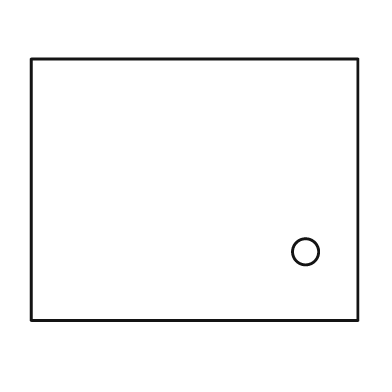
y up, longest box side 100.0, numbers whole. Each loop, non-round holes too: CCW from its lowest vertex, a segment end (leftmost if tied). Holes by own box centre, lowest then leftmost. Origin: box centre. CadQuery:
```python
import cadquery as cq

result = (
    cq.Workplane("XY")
    .moveTo(-50.0, -40.0)
    .lineTo(50.0, -40.0)
    .lineTo(50.0, 40.0)
    .lineTo(-50.0, 40.0)
    .close()
    .moveTo(34.0, -19.0)
    .circle(4.0)
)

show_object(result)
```